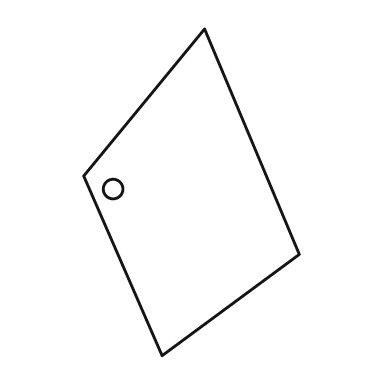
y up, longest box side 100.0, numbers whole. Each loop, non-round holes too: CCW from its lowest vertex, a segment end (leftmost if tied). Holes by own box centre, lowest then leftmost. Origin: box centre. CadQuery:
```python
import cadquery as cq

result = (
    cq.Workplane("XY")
    .moveTo(-9.0, -50.0)
    .lineTo(33.0, -19.0)
    .lineTo(4.0, 50.0)
    .lineTo(-33.0, 5.0)
    .close()
    .moveTo(-24.0, 1.0)
    .circle(3.0)
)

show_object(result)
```